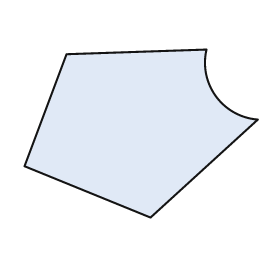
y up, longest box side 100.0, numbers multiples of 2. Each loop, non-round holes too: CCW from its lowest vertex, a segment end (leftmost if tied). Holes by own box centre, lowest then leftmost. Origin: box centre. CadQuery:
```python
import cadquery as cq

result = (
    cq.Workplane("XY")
    .moveTo(4.0, -36.0)
    .lineTo(50.0, 6.0)
    .threePointArc((32.0, 16.0), (28.0, 36.0))
    .lineTo(-32.0, 34.0)
    .lineTo(-50.0, -14.0)
    .close()
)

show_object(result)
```